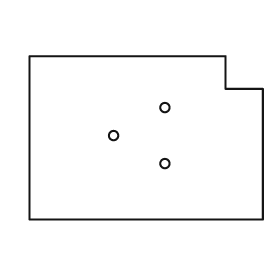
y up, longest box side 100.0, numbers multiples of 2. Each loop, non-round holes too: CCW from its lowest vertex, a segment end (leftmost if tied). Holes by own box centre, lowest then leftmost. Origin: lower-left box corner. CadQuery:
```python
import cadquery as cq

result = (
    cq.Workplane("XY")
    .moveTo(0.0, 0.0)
    .lineTo(100.0, 0.0)
    .lineTo(100.0, 56.0)
    .lineTo(84.0, 56.0)
    .lineTo(84.0, 70.0)
    .lineTo(0.0, 70.0)
    .close()
    .moveTo(58.0, 24.0)
    .circle(2.0)
    .moveTo(36.0, 36.0)
    .circle(2.0)
    .moveTo(58.0, 48.0)
    .circle(2.0)
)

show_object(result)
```